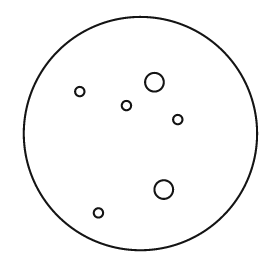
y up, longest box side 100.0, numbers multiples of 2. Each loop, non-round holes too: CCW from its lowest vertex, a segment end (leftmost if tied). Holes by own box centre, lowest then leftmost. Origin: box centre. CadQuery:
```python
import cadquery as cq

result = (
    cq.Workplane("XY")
    .moveTo(0.0, 0.0)
    .circle(50.0)
    .moveTo(-18.0, -34.0)
    .circle(2.0)
    .moveTo(10.0, -24.0)
    .circle(4.0)
    .moveTo(16.0, 6.0)
    .circle(2.0)
    .moveTo(-6.0, 12.0)
    .circle(2.0)
    .moveTo(-26.0, 18.0)
    .circle(2.0)
    .moveTo(6.0, 22.0)
    .circle(4.0)
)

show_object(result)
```